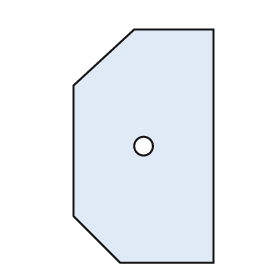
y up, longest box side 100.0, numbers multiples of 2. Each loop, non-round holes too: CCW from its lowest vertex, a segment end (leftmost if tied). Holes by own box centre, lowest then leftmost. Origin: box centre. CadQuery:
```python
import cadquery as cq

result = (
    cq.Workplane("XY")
    .moveTo(-10.0, -50.0)
    .lineTo(30.0, -50.0)
    .lineTo(30.0, 50.0)
    .lineTo(-4.0, 50.0)
    .lineTo(-30.0, 26.0)
    .lineTo(-30.0, -30.0)
    .close()
    .moveTo(0.0, 0.0)
    .circle(4.0)
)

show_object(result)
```